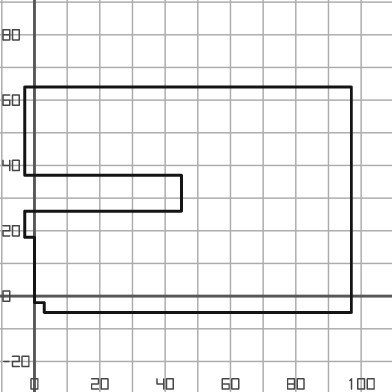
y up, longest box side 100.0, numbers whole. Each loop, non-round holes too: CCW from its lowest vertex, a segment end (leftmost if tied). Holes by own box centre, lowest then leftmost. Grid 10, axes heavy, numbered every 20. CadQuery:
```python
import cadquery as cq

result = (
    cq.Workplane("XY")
    .moveTo(3.0, -5.0)
    .lineTo(97.0, -5.0)
    .lineTo(97.0, 64.0)
    .lineTo(-3.0, 64.0)
    .lineTo(-3.0, 37.0)
    .lineTo(45.0, 37.0)
    .lineTo(45.0, 26.0)
    .lineTo(-3.0, 26.0)
    .lineTo(-3.0, 18.0)
    .lineTo(0.0, 18.0)
    .lineTo(0.0, -2.0)
    .lineTo(3.0, -2.0)
    .close()
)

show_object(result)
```